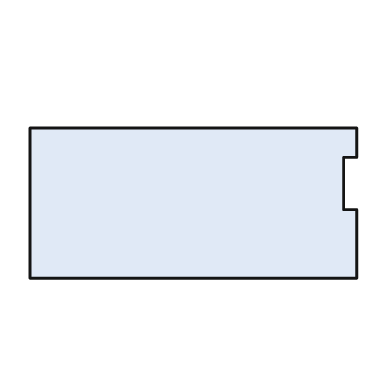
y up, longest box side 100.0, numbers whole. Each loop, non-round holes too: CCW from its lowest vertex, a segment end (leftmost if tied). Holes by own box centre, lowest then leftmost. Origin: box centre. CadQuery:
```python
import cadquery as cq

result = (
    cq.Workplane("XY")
    .moveTo(-50.0, -23.0)
    .lineTo(50.0, -23.0)
    .lineTo(50.0, -2.0)
    .lineTo(46.0, -2.0)
    .lineTo(46.0, 14.0)
    .lineTo(50.0, 14.0)
    .lineTo(50.0, 23.0)
    .lineTo(-50.0, 23.0)
    .close()
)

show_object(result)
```